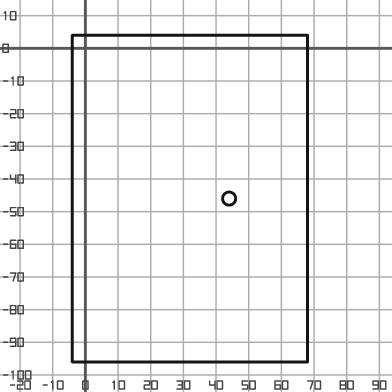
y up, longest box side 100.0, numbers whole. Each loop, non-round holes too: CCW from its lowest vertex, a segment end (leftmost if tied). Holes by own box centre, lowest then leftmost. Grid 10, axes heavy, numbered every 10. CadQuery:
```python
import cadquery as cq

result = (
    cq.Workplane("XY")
    .moveTo(-4.0, -96.0)
    .lineTo(68.0, -96.0)
    .lineTo(68.0, 4.0)
    .lineTo(-4.0, 4.0)
    .close()
    .moveTo(44.0, -46.0)
    .circle(2.0)
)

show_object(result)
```